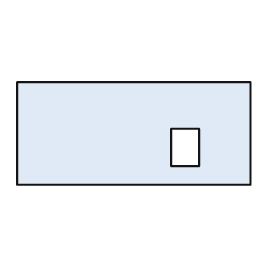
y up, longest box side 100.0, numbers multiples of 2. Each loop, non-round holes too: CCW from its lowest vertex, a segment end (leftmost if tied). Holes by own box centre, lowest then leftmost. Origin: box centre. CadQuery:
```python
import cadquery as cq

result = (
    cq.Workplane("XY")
    .moveTo(-50.0, -22.0)
    .lineTo(50.0, -22.0)
    .lineTo(50.0, 22.0)
    .lineTo(-50.0, 22.0)
    .close()
    .moveTo(16.0, -14.0)
    .lineTo(28.0, -14.0)
    .lineTo(28.0, 2.0)
    .lineTo(16.0, 2.0)
    .close()
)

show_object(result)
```